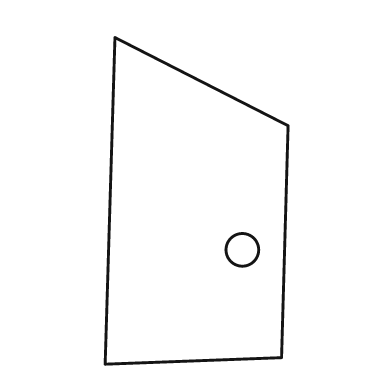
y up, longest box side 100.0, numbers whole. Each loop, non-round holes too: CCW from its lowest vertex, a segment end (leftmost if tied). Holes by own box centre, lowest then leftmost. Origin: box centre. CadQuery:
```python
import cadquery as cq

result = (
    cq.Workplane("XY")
    .moveTo(-28.0, -50.0)
    .lineTo(26.0, -48.0)
    .lineTo(28.0, 23.0)
    .lineTo(-25.0, 50.0)
    .close()
    .moveTo(14.0, -15.0)
    .circle(5.0)
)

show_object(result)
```